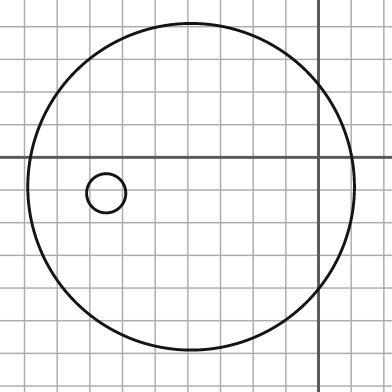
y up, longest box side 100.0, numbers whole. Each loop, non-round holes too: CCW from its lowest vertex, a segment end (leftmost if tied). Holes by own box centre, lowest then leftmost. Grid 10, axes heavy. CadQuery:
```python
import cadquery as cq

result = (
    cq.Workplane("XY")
    .moveTo(-39.0, -9.0)
    .circle(50.0)
    .moveTo(-65.0, -11.0)
    .circle(6.0)
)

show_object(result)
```